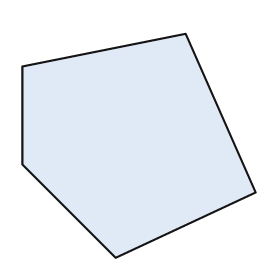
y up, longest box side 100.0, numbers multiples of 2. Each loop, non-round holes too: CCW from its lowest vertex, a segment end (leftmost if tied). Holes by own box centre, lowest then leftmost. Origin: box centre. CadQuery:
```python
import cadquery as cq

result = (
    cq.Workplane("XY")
    .moveTo(-10.0, -48.0)
    .lineTo(50.0, -20.0)
    .lineTo(20.0, 48.0)
    .lineTo(-50.0, 34.0)
    .lineTo(-50.0, -8.0)
    .close()
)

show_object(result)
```